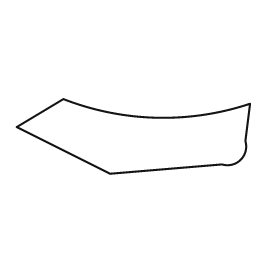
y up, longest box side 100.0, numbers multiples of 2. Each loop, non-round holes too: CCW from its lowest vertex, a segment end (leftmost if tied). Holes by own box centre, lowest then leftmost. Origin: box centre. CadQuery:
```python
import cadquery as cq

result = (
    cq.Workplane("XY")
    .moveTo(-10.0, -16.0)
    .lineTo(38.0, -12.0)
    .threePointArc((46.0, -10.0), (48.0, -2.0))
    .lineTo(50.0, 14.0)
    .threePointArc((10.0, 8.0), (-30.0, 16.0))
    .lineTo(-50.0, 4.0)
    .close()
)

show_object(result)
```